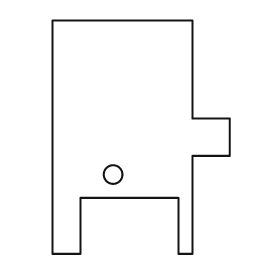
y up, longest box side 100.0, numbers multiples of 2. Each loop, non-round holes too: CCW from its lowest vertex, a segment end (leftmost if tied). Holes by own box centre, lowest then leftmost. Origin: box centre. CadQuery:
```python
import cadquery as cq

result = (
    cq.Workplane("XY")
    .moveTo(-38.0, -50.0)
    .lineTo(-26.0, -50.0)
    .lineTo(-26.0, -26.0)
    .lineTo(16.0, -26.0)
    .lineTo(16.0, -50.0)
    .lineTo(22.0, -50.0)
    .lineTo(22.0, -8.0)
    .lineTo(38.0, -8.0)
    .lineTo(38.0, 8.0)
    .lineTo(22.0, 8.0)
    .lineTo(22.0, 50.0)
    .lineTo(-38.0, 50.0)
    .close()
    .moveTo(-12.0, -16.0)
    .circle(4.0)
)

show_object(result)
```